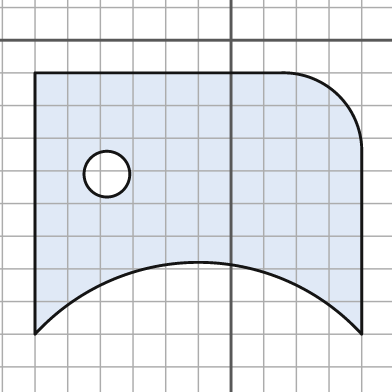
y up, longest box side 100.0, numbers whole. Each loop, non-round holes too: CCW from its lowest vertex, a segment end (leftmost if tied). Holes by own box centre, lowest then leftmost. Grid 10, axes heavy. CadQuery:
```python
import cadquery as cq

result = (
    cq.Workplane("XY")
    .moveTo(-60.0, -90.0)
    .threePointArc((-10.0, -68.0), (40.0, -90.0))
    .lineTo(40.0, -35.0)
    .threePointArc((33.0, -17.0), (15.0, -10.0))
    .lineTo(-60.0, -10.0)
    .close()
    .moveTo(-38.0, -41.0)
    .circle(7.0)
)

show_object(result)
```